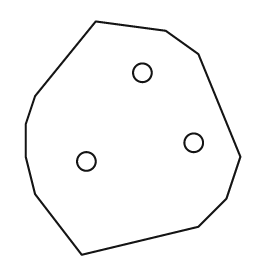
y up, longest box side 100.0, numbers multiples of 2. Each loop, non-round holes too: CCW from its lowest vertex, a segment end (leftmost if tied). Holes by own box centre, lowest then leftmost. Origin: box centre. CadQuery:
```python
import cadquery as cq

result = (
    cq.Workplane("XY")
    .moveTo(-22.0, -50.0)
    .lineTo(28.0, -38.0)
    .lineTo(40.0, -26.0)
    .lineTo(46.0, -8.0)
    .lineTo(28.0, 36.0)
    .lineTo(14.0, 46.0)
    .lineTo(-16.0, 50.0)
    .lineTo(-42.0, 18.0)
    .lineTo(-46.0, 6.0)
    .lineTo(-46.0, -8.0)
    .lineTo(-42.0, -24.0)
    .close()
    .moveTo(-20.0, -10.0)
    .circle(4.0)
    .moveTo(26.0, -2.0)
    .circle(4.0)
    .moveTo(4.0, 28.0)
    .circle(4.0)
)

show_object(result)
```